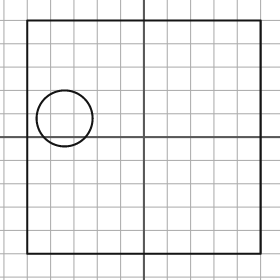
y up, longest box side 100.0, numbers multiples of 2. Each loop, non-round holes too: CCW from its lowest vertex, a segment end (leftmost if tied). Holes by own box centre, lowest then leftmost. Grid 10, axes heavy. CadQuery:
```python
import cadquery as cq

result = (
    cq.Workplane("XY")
    .moveTo(-50.0, -50.0)
    .lineTo(50.0, -50.0)
    .lineTo(50.0, 50.0)
    .lineTo(-50.0, 50.0)
    .close()
    .moveTo(-34.0, 8.0)
    .circle(12.0)
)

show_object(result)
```